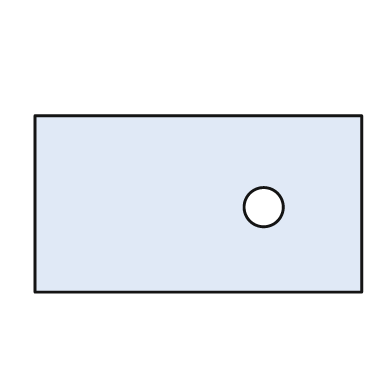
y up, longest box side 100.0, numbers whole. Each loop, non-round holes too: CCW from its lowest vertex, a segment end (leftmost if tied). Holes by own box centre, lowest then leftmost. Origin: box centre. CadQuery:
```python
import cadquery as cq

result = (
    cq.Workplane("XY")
    .moveTo(-50.0, -27.0)
    .lineTo(50.0, -27.0)
    .lineTo(50.0, 27.0)
    .lineTo(-50.0, 27.0)
    .close()
    .moveTo(20.0, -1.0)
    .circle(6.0)
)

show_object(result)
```